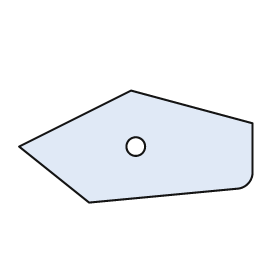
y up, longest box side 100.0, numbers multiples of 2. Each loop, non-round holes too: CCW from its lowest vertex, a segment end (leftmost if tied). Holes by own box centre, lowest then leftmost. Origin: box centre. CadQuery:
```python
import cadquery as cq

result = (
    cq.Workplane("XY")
    .moveTo(-20.0, -24.0)
    .lineTo(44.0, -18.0)
    .threePointArc((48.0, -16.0), (50.0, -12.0))
    .lineTo(50.0, 10.0)
    .lineTo(-2.0, 24.0)
    .lineTo(-50.0, 0.0)
    .close()
    .moveTo(0.0, 0.0)
    .circle(4.0)
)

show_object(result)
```